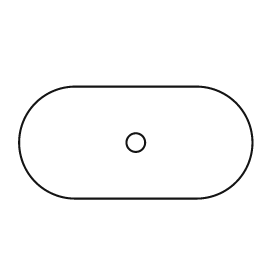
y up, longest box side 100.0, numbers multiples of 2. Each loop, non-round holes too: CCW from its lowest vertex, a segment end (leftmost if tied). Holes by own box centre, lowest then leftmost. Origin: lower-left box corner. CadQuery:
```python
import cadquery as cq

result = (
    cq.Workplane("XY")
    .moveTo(24.0, 0.0)
    .lineTo(76.0, 0.0)
    .threePointArc((100.0, 24.0), (76.0, 48.0))
    .lineTo(24.0, 48.0)
    .threePointArc((0.0, 24.0), (24.0, 0.0))
    .close()
    .moveTo(50.0, 24.0)
    .circle(4.0)
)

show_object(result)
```